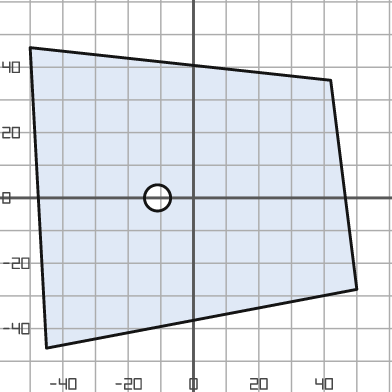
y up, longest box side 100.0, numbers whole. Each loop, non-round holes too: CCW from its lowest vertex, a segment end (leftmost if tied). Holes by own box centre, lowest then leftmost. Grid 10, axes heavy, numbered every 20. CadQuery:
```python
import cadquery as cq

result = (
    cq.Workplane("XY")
    .moveTo(-45.0, -46.0)
    .lineTo(50.0, -28.0)
    .lineTo(42.0, 36.0)
    .lineTo(-50.0, 46.0)
    .close()
    .moveTo(-11.0, 0.0)
    .circle(4.0)
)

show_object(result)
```